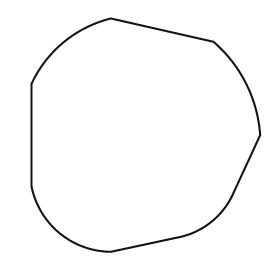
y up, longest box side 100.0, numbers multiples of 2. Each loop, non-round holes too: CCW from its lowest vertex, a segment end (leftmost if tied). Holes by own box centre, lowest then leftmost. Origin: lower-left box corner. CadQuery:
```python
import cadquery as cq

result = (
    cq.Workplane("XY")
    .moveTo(34.0, 0.0)
    .lineTo(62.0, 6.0)
    .threePointArc((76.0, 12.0), (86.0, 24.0))
    .lineTo(98.0, 50.0)
    .threePointArc((92.0, 72.0), (78.0, 90.0))
    .lineTo(34.0, 100.0)
    .threePointArc((14.0, 90.0), (0.0, 72.0))
    .lineTo(0.0, 28.0)
    .threePointArc((12.0, 8.0), (34.0, 0.0))
    .close()
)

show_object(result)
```